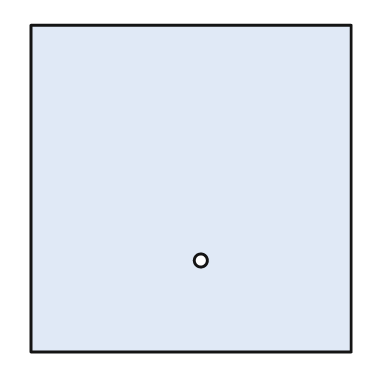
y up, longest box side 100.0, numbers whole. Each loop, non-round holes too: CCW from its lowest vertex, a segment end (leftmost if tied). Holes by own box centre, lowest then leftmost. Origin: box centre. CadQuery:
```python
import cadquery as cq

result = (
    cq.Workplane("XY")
    .moveTo(-49.0, -50.0)
    .lineTo(49.0, -50.0)
    .lineTo(49.0, 50.0)
    .lineTo(-49.0, 50.0)
    .close()
    .moveTo(3.0, -22.0)
    .circle(2.0)
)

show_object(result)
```